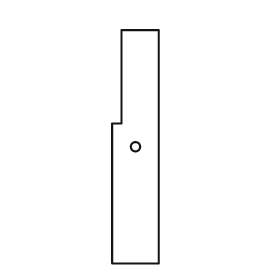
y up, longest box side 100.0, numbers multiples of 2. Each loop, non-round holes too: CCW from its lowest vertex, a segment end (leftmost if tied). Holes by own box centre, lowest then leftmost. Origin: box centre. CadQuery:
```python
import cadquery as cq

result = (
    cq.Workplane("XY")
    .moveTo(-10.0, -50.0)
    .lineTo(10.0, -50.0)
    .lineTo(10.0, 50.0)
    .lineTo(-6.0, 50.0)
    .lineTo(-6.0, 10.0)
    .lineTo(-10.0, 10.0)
    .close()
    .moveTo(0.0, 0.0)
    .circle(2.0)
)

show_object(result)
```